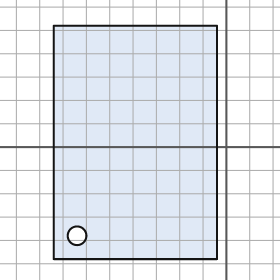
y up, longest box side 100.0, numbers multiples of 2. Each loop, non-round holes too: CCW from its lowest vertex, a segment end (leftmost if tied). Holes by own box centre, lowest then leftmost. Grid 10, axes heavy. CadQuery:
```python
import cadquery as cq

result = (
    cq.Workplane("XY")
    .moveTo(-74.0, -48.0)
    .lineTo(-4.0, -48.0)
    .lineTo(-4.0, 52.0)
    .lineTo(-74.0, 52.0)
    .close()
    .moveTo(-64.0, -38.0)
    .circle(4.0)
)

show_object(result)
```